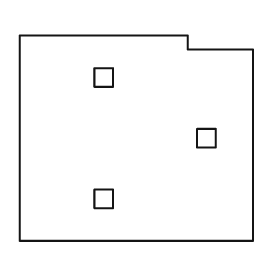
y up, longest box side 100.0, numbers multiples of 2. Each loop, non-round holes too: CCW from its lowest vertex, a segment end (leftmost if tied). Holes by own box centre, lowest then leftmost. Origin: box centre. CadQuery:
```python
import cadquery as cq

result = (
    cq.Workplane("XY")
    .moveTo(-50.0, -44.0)
    .lineTo(50.0, -44.0)
    .lineTo(50.0, 38.0)
    .lineTo(22.0, 38.0)
    .lineTo(22.0, 44.0)
    .lineTo(-50.0, 44.0)
    .close()
    .moveTo(-18.0, -30.0)
    .lineTo(-10.0, -30.0)
    .lineTo(-10.0, -22.0)
    .lineTo(-18.0, -22.0)
    .close()
    .moveTo(26.0, -4.0)
    .lineTo(34.0, -4.0)
    .lineTo(34.0, 4.0)
    .lineTo(26.0, 4.0)
    .close()
    .moveTo(-18.0, 22.0)
    .lineTo(-10.0, 22.0)
    .lineTo(-10.0, 30.0)
    .lineTo(-18.0, 30.0)
    .close()
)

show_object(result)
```